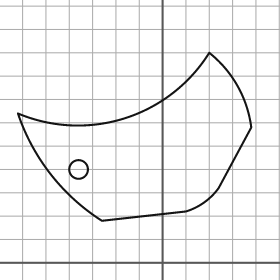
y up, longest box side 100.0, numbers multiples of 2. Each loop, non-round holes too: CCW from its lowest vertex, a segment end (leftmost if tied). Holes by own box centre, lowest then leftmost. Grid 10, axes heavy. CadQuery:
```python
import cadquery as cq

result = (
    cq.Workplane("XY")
    .moveTo(-26.0, 18.0)
    .lineTo(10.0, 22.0)
    .threePointArc((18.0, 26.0), (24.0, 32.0))
    .lineTo(38.0, 58.0)
    .threePointArc((32.0, 76.0), (20.0, 90.0))
    .threePointArc((-16.0, 62.0), (-62.0, 64.0))
    .threePointArc((-48.0, 38.0), (-26.0, 18.0))
    .close()
    .moveTo(-36.0, 40.0)
    .circle(4.0)
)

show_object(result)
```